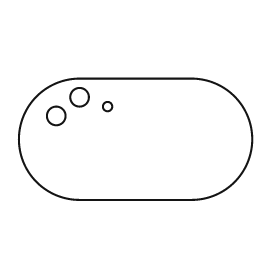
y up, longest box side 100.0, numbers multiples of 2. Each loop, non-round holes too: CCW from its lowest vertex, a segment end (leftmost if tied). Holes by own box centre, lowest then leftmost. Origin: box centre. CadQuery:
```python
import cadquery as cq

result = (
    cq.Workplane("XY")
    .moveTo(-24.0, -26.0)
    .lineTo(24.0, -26.0)
    .threePointArc((50.0, 0.0), (24.0, 26.0))
    .lineTo(-24.0, 26.0)
    .threePointArc((-50.0, 0.0), (-24.0, -26.0))
    .close()
    .moveTo(-34.0, 10.0)
    .circle(4.0)
    .moveTo(-12.0, 14.0)
    .circle(2.0)
    .moveTo(-24.0, 18.0)
    .circle(4.0)
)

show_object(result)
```